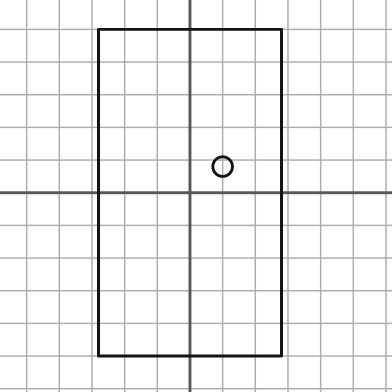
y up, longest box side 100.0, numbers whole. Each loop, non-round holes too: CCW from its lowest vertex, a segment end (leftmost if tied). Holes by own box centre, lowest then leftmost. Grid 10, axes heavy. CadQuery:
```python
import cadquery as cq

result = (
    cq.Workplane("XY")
    .moveTo(-28.0, -50.0)
    .lineTo(28.0, -50.0)
    .lineTo(28.0, 50.0)
    .lineTo(-28.0, 50.0)
    .close()
    .moveTo(10.0, 8.0)
    .circle(3.0)
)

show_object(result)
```